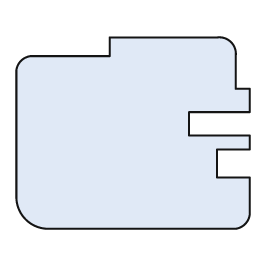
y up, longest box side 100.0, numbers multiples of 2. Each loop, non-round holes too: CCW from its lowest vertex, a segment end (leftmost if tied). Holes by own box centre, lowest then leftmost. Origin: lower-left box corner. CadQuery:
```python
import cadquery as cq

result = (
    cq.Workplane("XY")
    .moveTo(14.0, 0.0)
    .lineTo(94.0, 0.0)
    .threePointArc((98.0, 2.0), (100.0, 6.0))
    .lineTo(100.0, 22.0)
    .lineTo(86.0, 22.0)
    .lineTo(86.0, 34.0)
    .lineTo(100.0, 34.0)
    .lineTo(100.0, 40.0)
    .lineTo(74.0, 40.0)
    .lineTo(74.0, 50.0)
    .lineTo(100.0, 50.0)
    .lineTo(100.0, 60.0)
    .lineTo(94.0, 60.0)
    .lineTo(94.0, 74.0)
    .threePointArc((92.0, 80.0), (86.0, 82.0))
    .lineTo(40.0, 82.0)
    .lineTo(40.0, 74.0)
    .lineTo(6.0, 74.0)
    .threePointArc((2.0, 72.0), (0.0, 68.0))
    .lineTo(0.0, 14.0)
    .threePointArc((4.0, 4.0), (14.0, 0.0))
    .close()
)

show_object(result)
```